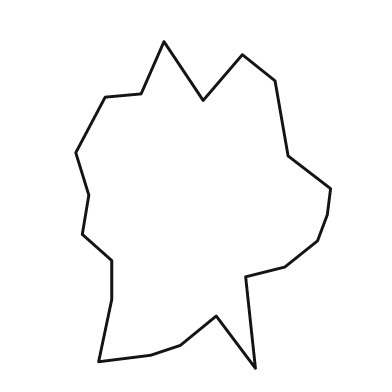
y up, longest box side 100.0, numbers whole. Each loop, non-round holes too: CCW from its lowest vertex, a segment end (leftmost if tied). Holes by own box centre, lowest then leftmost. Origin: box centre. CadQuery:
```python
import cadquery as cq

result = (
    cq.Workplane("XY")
    .moveTo(16.0, -50.0)
    .lineTo(13.0, -22.0)
    .lineTo(25.0, -19.0)
    .lineTo(35.0, -11.0)
    .lineTo(38.0, -3.0)
    .lineTo(39.0, 5.0)
    .lineTo(26.0, 15.0)
    .lineTo(22.0, 38.0)
    .lineTo(12.0, 46.0)
    .lineTo(0.0, 32.0)
    .lineTo(-12.0, 50.0)
    .lineTo(-19.0, 34.0)
    .lineTo(-30.0, 33.0)
    .lineTo(-39.0, 16.0)
    .lineTo(-35.0, 3.0)
    .lineTo(-37.0, -9.0)
    .lineTo(-28.0, -17.0)
    .lineTo(-28.0, -29.0)
    .lineTo(-32.0, -48.0)
    .lineTo(-16.0, -46.0)
    .lineTo(-7.0, -43.0)
    .lineTo(4.0, -34.0)
    .close()
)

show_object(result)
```